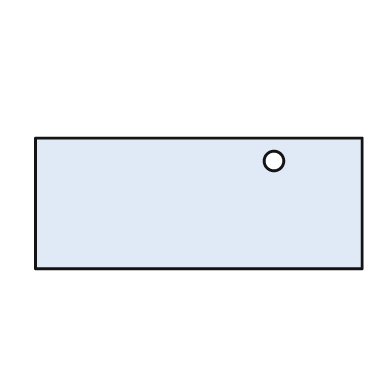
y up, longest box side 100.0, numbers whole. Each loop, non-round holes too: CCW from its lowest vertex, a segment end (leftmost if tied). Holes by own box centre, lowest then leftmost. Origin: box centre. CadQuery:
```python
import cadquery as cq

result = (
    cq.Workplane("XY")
    .moveTo(-50.0, -20.0)
    .lineTo(50.0, -20.0)
    .lineTo(50.0, 20.0)
    .lineTo(-50.0, 20.0)
    .close()
    .moveTo(23.0, 13.0)
    .circle(3.0)
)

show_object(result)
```